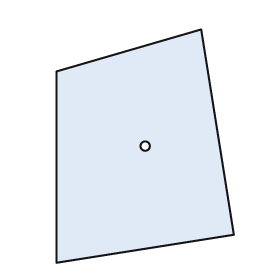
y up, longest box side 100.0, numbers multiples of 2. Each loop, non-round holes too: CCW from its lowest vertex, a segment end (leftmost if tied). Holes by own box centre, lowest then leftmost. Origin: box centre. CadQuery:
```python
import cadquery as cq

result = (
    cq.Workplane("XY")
    .moveTo(-38.0, -50.0)
    .lineTo(38.0, -38.0)
    .lineTo(24.0, 50.0)
    .lineTo(-38.0, 32.0)
    .close()
    .moveTo(0.0, 0.0)
    .circle(2.0)
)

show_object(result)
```